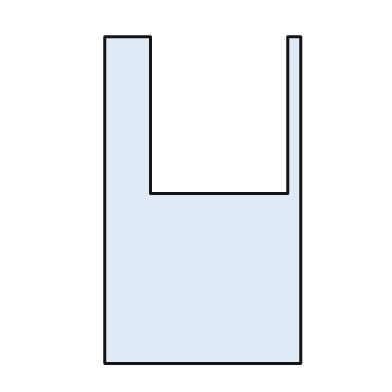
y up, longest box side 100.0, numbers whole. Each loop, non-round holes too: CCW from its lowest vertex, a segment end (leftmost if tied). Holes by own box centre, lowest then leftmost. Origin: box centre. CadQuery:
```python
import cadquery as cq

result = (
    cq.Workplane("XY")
    .moveTo(-30.0, -50.0)
    .lineTo(30.0, -50.0)
    .lineTo(30.0, 50.0)
    .lineTo(26.0, 50.0)
    .lineTo(26.0, 2.0)
    .lineTo(-16.0, 2.0)
    .lineTo(-16.0, 50.0)
    .lineTo(-30.0, 50.0)
    .close()
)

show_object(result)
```